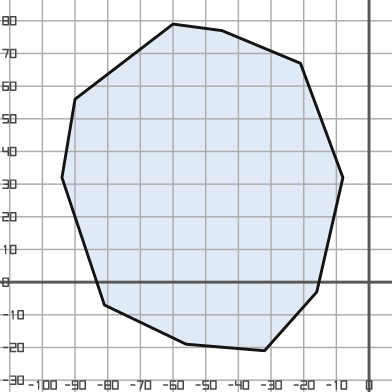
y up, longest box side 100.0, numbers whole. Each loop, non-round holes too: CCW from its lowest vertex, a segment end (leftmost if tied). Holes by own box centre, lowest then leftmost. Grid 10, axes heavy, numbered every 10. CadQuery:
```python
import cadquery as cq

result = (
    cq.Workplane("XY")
    .moveTo(-32.0, -21.0)
    .lineTo(-16.0, -3.0)
    .lineTo(-8.0, 32.0)
    .lineTo(-21.0, 67.0)
    .lineTo(-45.0, 77.0)
    .lineTo(-60.0, 79.0)
    .lineTo(-90.0, 56.0)
    .lineTo(-94.0, 32.0)
    .lineTo(-81.0, -7.0)
    .lineTo(-56.0, -19.0)
    .close()
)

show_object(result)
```